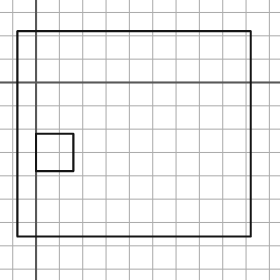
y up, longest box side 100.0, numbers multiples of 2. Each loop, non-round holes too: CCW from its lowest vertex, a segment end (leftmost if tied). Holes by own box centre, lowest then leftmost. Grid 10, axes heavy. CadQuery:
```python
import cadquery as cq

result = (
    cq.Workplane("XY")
    .moveTo(-8.0, -66.0)
    .lineTo(92.0, -66.0)
    .lineTo(92.0, 22.0)
    .lineTo(-8.0, 22.0)
    .close()
    .moveTo(0.0, -38.0)
    .lineTo(16.0, -38.0)
    .lineTo(16.0, -22.0)
    .lineTo(0.0, -22.0)
    .close()
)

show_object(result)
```